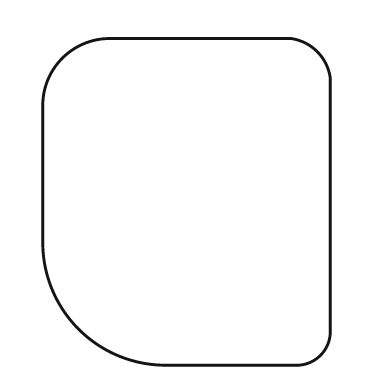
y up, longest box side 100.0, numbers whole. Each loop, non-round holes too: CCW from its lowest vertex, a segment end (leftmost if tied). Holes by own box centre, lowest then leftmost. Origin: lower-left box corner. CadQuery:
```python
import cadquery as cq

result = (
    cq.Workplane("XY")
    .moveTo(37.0, 0.0)
    .lineTo(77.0, 0.0)
    .threePointArc((85.0, 3.0), (88.0, 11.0))
    .lineTo(88.0, 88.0)
    .threePointArc((84.0, 96.0), (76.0, 100.0))
    .lineTo(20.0, 100.0)
    .threePointArc((6.0, 94.0), (0.0, 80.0))
    .lineTo(0.0, 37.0)
    .threePointArc((11.0, 11.0), (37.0, 0.0))
    .close()
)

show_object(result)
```